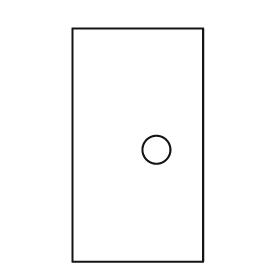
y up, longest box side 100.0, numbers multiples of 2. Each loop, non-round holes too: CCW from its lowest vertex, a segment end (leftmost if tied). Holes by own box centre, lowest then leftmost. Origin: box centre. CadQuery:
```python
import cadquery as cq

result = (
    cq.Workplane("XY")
    .moveTo(-28.0, -50.0)
    .lineTo(28.0, -50.0)
    .lineTo(28.0, 50.0)
    .lineTo(-28.0, 50.0)
    .close()
    .moveTo(8.0, -2.0)
    .circle(6.0)
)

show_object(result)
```